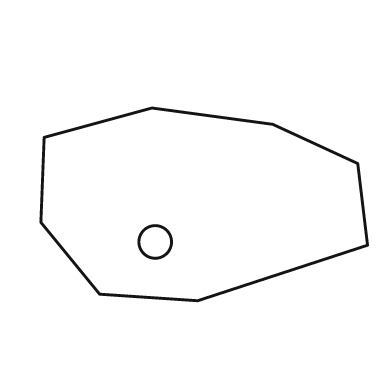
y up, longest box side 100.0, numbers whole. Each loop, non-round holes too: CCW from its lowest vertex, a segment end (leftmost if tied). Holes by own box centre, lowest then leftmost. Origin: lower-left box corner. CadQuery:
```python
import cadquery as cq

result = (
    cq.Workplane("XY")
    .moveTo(48.0, 0.0)
    .lineTo(100.0, 17.0)
    .lineTo(97.0, 42.0)
    .lineTo(71.0, 54.0)
    .lineTo(34.0, 59.0)
    .lineTo(1.0, 50.0)
    .lineTo(0.0, 24.0)
    .lineTo(18.0, 2.0)
    .close()
    .moveTo(35.0, 18.0)
    .circle(5.0)
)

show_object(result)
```